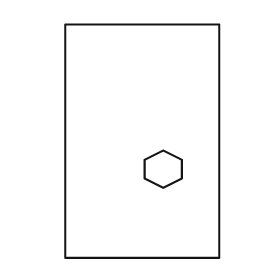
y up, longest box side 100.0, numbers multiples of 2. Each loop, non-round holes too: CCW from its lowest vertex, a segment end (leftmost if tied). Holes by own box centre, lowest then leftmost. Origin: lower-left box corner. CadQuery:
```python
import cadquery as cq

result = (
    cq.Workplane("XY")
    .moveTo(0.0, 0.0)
    .lineTo(66.0, 0.0)
    .lineTo(66.0, 100.0)
    .lineTo(0.0, 100.0)
    .close()
    .moveTo(42.0, 30.0)
    .lineTo(50.0, 34.0)
    .lineTo(50.0, 42.0)
    .lineTo(42.0, 46.0)
    .lineTo(34.0, 42.0)
    .lineTo(34.0, 34.0)
    .close()
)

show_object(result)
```